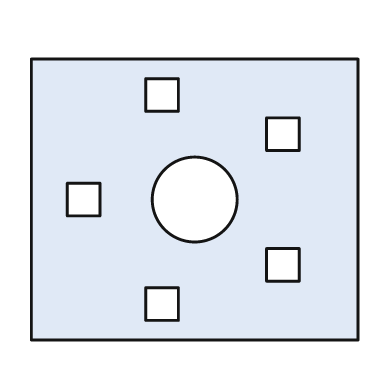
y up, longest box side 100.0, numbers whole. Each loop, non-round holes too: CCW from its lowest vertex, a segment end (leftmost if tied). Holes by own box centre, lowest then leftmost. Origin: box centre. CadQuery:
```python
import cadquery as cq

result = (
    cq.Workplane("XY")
    .moveTo(-50.0, -43.0)
    .lineTo(50.0, -43.0)
    .lineTo(50.0, 43.0)
    .lineTo(-50.0, 43.0)
    .close()
    .moveTo(-15.0, -37.0)
    .lineTo(-5.0, -37.0)
    .lineTo(-5.0, -27.0)
    .lineTo(-15.0, -27.0)
    .close()
    .moveTo(22.0, -25.0)
    .lineTo(32.0, -25.0)
    .lineTo(32.0, -15.0)
    .lineTo(22.0, -15.0)
    .close()
    .moveTo(-39.0, -5.0)
    .lineTo(-29.0, -5.0)
    .lineTo(-29.0, 5.0)
    .lineTo(-39.0, 5.0)
    .close()
    .moveTo(0.0, 0.0)
    .circle(13.0)
    .moveTo(22.0, 15.0)
    .lineTo(32.0, 15.0)
    .lineTo(32.0, 25.0)
    .lineTo(22.0, 25.0)
    .close()
    .moveTo(-15.0, 27.0)
    .lineTo(-5.0, 27.0)
    .lineTo(-5.0, 37.0)
    .lineTo(-15.0, 37.0)
    .close()
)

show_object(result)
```